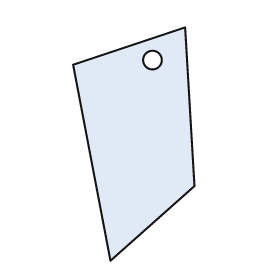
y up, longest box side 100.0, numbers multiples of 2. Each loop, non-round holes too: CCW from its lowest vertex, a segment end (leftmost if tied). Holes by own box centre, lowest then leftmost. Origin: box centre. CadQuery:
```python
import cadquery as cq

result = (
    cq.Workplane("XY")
    .moveTo(-10.0, -50.0)
    .lineTo(26.0, -18.0)
    .lineTo(22.0, 50.0)
    .lineTo(-26.0, 34.0)
    .close()
    .moveTo(8.0, 36.0)
    .circle(4.0)
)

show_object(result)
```